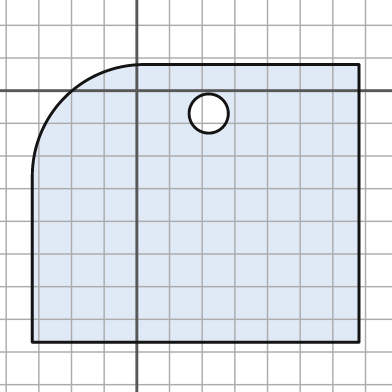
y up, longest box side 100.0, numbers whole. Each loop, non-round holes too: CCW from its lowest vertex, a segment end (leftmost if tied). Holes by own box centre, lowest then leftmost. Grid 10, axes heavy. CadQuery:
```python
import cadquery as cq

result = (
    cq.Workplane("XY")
    .moveTo(-32.0, -77.0)
    .lineTo(68.0, -77.0)
    .lineTo(68.0, 8.0)
    .lineTo(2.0, 8.0)
    .threePointArc((-22.0, -2.0), (-32.0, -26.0))
    .close()
    .moveTo(22.0, -7.0)
    .circle(6.0)
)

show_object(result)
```